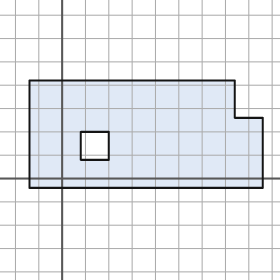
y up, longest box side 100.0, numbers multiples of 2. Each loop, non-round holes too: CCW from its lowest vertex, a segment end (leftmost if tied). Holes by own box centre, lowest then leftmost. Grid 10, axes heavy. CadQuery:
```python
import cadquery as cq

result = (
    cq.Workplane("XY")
    .moveTo(-14.0, -4.0)
    .lineTo(86.0, -4.0)
    .lineTo(86.0, 26.0)
    .lineTo(74.0, 26.0)
    .lineTo(74.0, 42.0)
    .lineTo(-14.0, 42.0)
    .close()
    .moveTo(8.0, 8.0)
    .lineTo(20.0, 8.0)
    .lineTo(20.0, 20.0)
    .lineTo(8.0, 20.0)
    .close()
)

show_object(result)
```